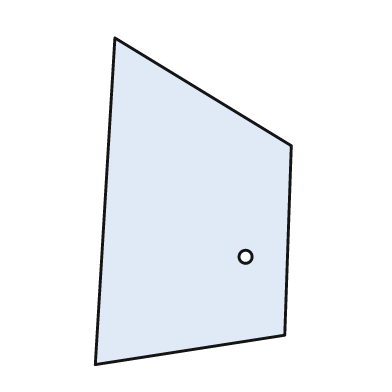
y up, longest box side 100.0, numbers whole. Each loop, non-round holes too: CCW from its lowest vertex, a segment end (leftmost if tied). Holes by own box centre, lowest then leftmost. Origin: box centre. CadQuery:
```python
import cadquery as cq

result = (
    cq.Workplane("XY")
    .moveTo(-30.0, -50.0)
    .lineTo(28.0, -41.0)
    .lineTo(30.0, 17.0)
    .lineTo(-24.0, 50.0)
    .close()
    .moveTo(16.0, -17.0)
    .circle(2.0)
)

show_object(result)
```